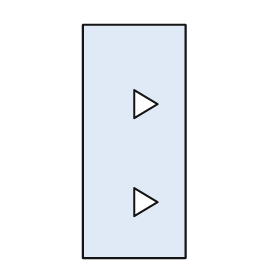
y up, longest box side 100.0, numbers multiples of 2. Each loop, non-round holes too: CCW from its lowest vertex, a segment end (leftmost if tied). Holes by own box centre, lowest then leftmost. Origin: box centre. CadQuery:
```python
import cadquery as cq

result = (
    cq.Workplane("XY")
    .moveTo(-22.0, -50.0)
    .lineTo(22.0, -50.0)
    .lineTo(22.0, 50.0)
    .lineTo(-22.0, 50.0)
    .close()
    .moveTo(0.0, -32.0)
    .lineTo(10.0, -26.0)
    .lineTo(0.0, -20.0)
    .close()
    .moveTo(0.0, 10.0)
    .lineTo(10.0, 16.0)
    .lineTo(0.0, 22.0)
    .close()
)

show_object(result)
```